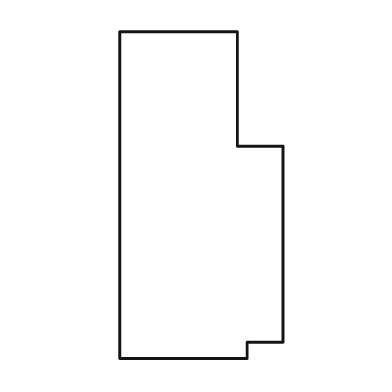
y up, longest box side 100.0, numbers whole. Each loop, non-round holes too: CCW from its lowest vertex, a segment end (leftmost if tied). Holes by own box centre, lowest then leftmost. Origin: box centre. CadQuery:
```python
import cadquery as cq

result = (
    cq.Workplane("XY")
    .moveTo(-25.0, -50.0)
    .lineTo(14.0, -50.0)
    .lineTo(14.0, -45.0)
    .lineTo(25.0, -45.0)
    .lineTo(25.0, 15.0)
    .lineTo(11.0, 15.0)
    .lineTo(11.0, 50.0)
    .lineTo(-25.0, 50.0)
    .close()
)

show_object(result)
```